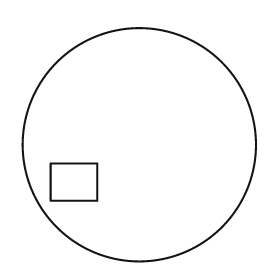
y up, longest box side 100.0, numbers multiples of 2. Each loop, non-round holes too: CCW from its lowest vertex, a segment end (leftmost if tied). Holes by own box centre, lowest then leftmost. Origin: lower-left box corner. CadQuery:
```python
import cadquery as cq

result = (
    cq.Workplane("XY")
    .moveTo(50.0, 50.0)
    .circle(50.0)
    .moveTo(12.0, 26.0)
    .lineTo(32.0, 26.0)
    .lineTo(32.0, 42.0)
    .lineTo(12.0, 42.0)
    .close()
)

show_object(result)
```